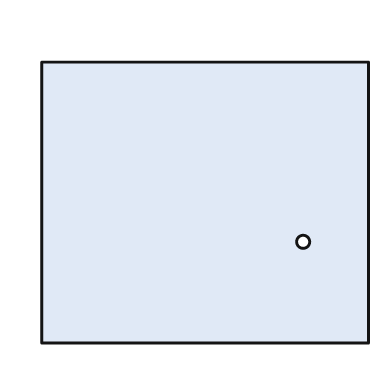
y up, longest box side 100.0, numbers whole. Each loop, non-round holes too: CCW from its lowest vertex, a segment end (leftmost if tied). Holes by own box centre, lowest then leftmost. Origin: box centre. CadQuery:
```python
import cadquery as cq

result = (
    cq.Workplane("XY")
    .moveTo(-50.0, -43.0)
    .lineTo(50.0, -43.0)
    .lineTo(50.0, 43.0)
    .lineTo(-50.0, 43.0)
    .close()
    .moveTo(30.0, -12.0)
    .circle(2.0)
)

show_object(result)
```